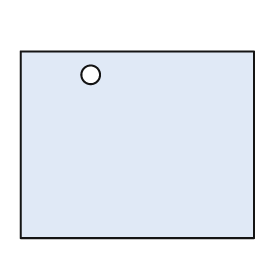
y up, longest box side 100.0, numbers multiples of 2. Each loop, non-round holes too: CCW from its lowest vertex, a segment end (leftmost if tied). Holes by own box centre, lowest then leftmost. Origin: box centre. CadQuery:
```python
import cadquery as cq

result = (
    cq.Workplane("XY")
    .moveTo(-50.0, -40.0)
    .lineTo(50.0, -40.0)
    .lineTo(50.0, 40.0)
    .lineTo(-50.0, 40.0)
    .close()
    .moveTo(-20.0, 30.0)
    .circle(4.0)
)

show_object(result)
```